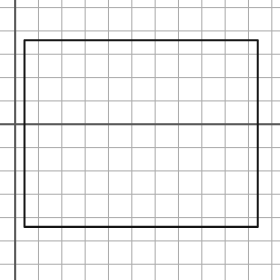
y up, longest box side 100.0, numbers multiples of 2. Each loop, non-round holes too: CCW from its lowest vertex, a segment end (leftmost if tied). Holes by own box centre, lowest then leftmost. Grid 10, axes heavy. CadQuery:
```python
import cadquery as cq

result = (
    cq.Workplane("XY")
    .moveTo(4.0, -44.0)
    .lineTo(104.0, -44.0)
    .lineTo(104.0, 36.0)
    .lineTo(4.0, 36.0)
    .close()
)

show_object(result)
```